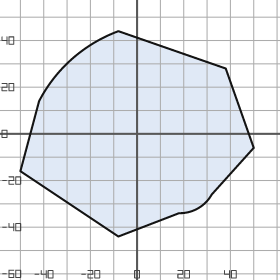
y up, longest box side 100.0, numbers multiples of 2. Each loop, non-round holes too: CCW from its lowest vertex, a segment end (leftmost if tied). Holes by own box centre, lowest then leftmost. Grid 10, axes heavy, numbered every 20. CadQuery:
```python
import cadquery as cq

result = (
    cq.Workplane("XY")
    .moveTo(-8.0, -44.0)
    .lineTo(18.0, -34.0)
    .threePointArc((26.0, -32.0), (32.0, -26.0))
    .lineTo(50.0, -6.0)
    .lineTo(38.0, 28.0)
    .lineTo(-8.0, 44.0)
    .threePointArc((-28.0, 32.0), (-42.0, 14.0))
    .lineTo(-50.0, -16.0)
    .close()
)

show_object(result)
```